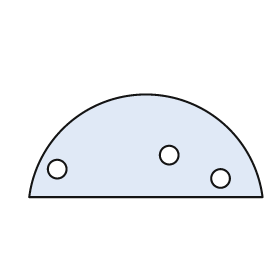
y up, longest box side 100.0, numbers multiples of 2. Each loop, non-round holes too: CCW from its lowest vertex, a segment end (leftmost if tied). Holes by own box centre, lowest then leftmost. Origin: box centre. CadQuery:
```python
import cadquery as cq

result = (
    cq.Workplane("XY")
    .moveTo(-50.0, -22.0)
    .lineTo(50.0, -22.0)
    .threePointArc((0.0, 22.0), (-50.0, -22.0))
    .close()
    .moveTo(32.0, -14.0)
    .circle(4.0)
    .moveTo(-38.0, -10.0)
    .circle(4.0)
    .moveTo(10.0, -4.0)
    .circle(4.0)
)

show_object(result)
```